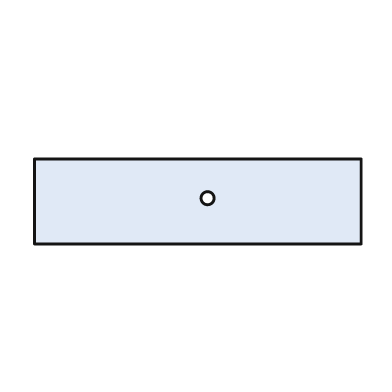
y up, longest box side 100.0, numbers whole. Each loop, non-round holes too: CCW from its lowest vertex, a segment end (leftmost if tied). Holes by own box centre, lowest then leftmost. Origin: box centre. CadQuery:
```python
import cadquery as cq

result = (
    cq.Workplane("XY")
    .moveTo(-50.0, -13.0)
    .lineTo(50.0, -13.0)
    .lineTo(50.0, 13.0)
    .lineTo(-50.0, 13.0)
    .close()
    .moveTo(3.0, 1.0)
    .circle(2.0)
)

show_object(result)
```